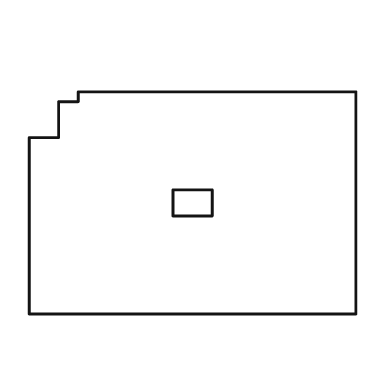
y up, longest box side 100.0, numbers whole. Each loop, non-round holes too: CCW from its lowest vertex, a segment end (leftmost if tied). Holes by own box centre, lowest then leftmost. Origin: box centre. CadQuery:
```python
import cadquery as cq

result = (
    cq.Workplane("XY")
    .moveTo(-50.0, -34.0)
    .lineTo(50.0, -34.0)
    .lineTo(50.0, 34.0)
    .lineTo(-35.0, 34.0)
    .lineTo(-35.0, 31.0)
    .lineTo(-41.0, 31.0)
    .lineTo(-41.0, 20.0)
    .lineTo(-50.0, 20.0)
    .close()
    .moveTo(-6.0, -4.0)
    .lineTo(6.0, -4.0)
    .lineTo(6.0, 4.0)
    .lineTo(-6.0, 4.0)
    .close()
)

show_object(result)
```